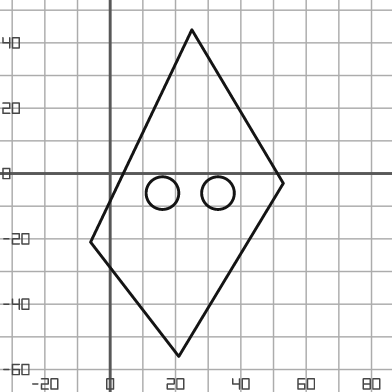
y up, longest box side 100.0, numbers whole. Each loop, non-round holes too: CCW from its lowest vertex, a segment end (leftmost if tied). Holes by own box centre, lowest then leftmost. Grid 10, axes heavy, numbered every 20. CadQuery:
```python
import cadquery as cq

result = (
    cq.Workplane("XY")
    .moveTo(21.0, -56.0)
    .lineTo(53.0, -3.0)
    .lineTo(25.0, 44.0)
    .lineTo(-6.0, -21.0)
    .close()
    .moveTo(16.0, -6.0)
    .circle(5.0)
    .moveTo(33.0, -6.0)
    .circle(5.0)
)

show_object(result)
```